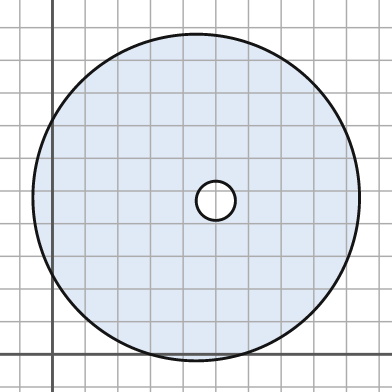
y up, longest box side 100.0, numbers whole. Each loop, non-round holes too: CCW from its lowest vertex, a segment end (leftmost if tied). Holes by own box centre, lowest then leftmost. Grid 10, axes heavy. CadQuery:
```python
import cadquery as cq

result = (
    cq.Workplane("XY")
    .moveTo(44.0, 48.0)
    .circle(50.0)
    .moveTo(50.0, 47.0)
    .circle(6.0)
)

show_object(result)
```